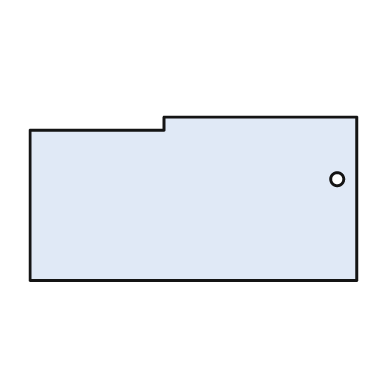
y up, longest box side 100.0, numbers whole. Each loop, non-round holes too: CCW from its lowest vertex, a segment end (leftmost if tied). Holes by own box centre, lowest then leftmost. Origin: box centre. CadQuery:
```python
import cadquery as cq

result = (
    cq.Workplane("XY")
    .moveTo(-50.0, -25.0)
    .lineTo(50.0, -25.0)
    .lineTo(50.0, 25.0)
    .lineTo(-9.0, 25.0)
    .lineTo(-9.0, 21.0)
    .lineTo(-50.0, 21.0)
    .close()
    .moveTo(44.0, 6.0)
    .circle(2.0)
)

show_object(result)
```